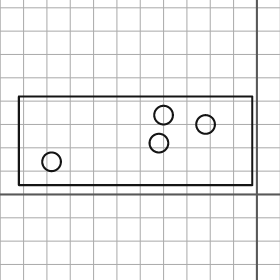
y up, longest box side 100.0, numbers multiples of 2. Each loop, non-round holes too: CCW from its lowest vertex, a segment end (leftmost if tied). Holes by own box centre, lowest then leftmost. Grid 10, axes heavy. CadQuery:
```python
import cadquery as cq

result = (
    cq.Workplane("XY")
    .moveTo(-102.0, 4.0)
    .lineTo(-2.0, 4.0)
    .lineTo(-2.0, 42.0)
    .lineTo(-102.0, 42.0)
    .close()
    .moveTo(-88.0, 14.0)
    .circle(4.0)
    .moveTo(-42.0, 22.0)
    .circle(4.0)
    .moveTo(-22.0, 30.0)
    .circle(4.0)
    .moveTo(-40.0, 34.0)
    .circle(4.0)
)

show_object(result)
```